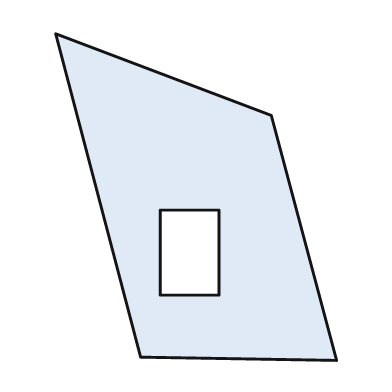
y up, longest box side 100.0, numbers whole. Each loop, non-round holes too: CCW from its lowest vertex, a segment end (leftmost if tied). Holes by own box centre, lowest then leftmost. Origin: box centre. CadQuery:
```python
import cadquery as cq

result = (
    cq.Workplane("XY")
    .moveTo(43.0, -50.0)
    .lineTo(23.0, 25.0)
    .lineTo(-43.0, 50.0)
    .lineTo(-17.0, -49.0)
    .close()
    .moveTo(-11.0, -30.0)
    .lineTo(7.0, -30.0)
    .lineTo(7.0, -4.0)
    .lineTo(-11.0, -4.0)
    .close()
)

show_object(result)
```